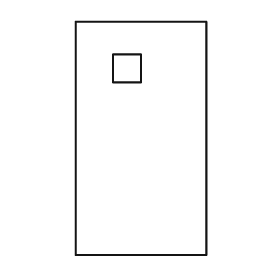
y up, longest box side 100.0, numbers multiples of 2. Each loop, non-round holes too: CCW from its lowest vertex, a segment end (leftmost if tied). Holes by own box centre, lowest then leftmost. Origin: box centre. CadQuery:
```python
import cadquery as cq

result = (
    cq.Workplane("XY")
    .moveTo(-28.0, -50.0)
    .lineTo(28.0, -50.0)
    .lineTo(28.0, 50.0)
    .lineTo(-28.0, 50.0)
    .close()
    .moveTo(-12.0, 24.0)
    .lineTo(0.0, 24.0)
    .lineTo(0.0, 36.0)
    .lineTo(-12.0, 36.0)
    .close()
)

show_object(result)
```